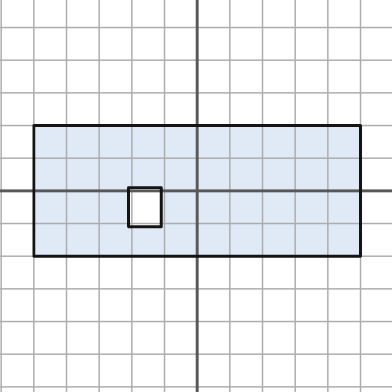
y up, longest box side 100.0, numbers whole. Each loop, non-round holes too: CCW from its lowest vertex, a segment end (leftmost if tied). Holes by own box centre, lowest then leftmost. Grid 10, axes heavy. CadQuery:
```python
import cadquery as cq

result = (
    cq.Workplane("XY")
    .moveTo(-50.0, -20.0)
    .lineTo(50.0, -20.0)
    .lineTo(50.0, 20.0)
    .lineTo(-50.0, 20.0)
    .close()
    .moveTo(-21.0, -11.0)
    .lineTo(-11.0, -11.0)
    .lineTo(-11.0, 1.0)
    .lineTo(-21.0, 1.0)
    .close()
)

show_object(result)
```